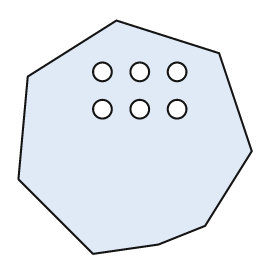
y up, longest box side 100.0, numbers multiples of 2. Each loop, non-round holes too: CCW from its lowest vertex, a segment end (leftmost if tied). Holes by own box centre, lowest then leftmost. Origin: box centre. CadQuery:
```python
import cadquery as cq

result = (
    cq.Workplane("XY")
    .moveTo(-18.0, -50.0)
    .lineTo(10.0, -46.0)
    .lineTo(30.0, -38.0)
    .lineTo(50.0, -6.0)
    .lineTo(36.0, 36.0)
    .lineTo(-8.0, 50.0)
    .lineTo(-46.0, 26.0)
    .lineTo(-50.0, -18.0)
    .close()
    .moveTo(-14.0, 12.0)
    .circle(4.0)
    .moveTo(2.0, 12.0)
    .circle(4.0)
    .moveTo(18.0, 12.0)
    .circle(4.0)
    .moveTo(-14.0, 28.0)
    .circle(4.0)
    .moveTo(2.0, 28.0)
    .circle(4.0)
    .moveTo(18.0, 28.0)
    .circle(4.0)
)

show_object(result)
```